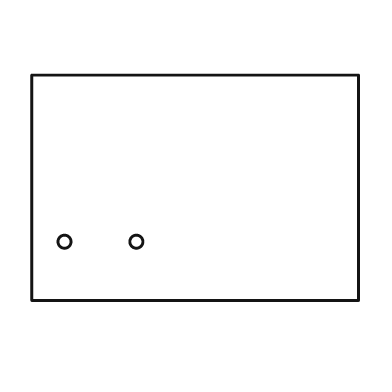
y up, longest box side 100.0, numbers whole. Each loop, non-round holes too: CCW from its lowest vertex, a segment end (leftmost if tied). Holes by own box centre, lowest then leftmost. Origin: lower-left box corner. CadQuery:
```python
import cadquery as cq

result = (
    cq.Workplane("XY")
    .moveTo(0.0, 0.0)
    .lineTo(100.0, 0.0)
    .lineTo(100.0, 69.0)
    .lineTo(0.0, 69.0)
    .close()
    .moveTo(10.0, 18.0)
    .circle(2.0)
    .moveTo(32.0, 18.0)
    .circle(2.0)
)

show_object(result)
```